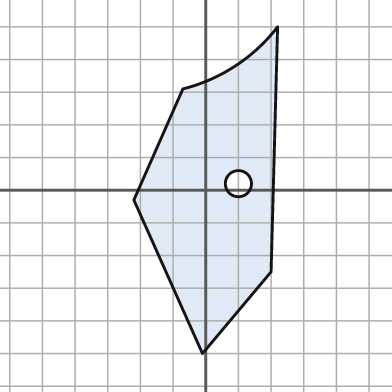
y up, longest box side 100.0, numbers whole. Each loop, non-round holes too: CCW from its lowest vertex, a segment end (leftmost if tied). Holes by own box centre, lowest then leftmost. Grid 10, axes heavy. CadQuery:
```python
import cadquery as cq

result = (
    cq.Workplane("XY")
    .moveTo(-1.0, -50.0)
    .lineTo(20.0, -25.0)
    .lineTo(22.0, 50.0)
    .threePointArc((9.0, 38.0), (-7.0, 31.0))
    .lineTo(-22.0, -3.0)
    .close()
    .moveTo(10.0, 2.0)
    .circle(4.0)
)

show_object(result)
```